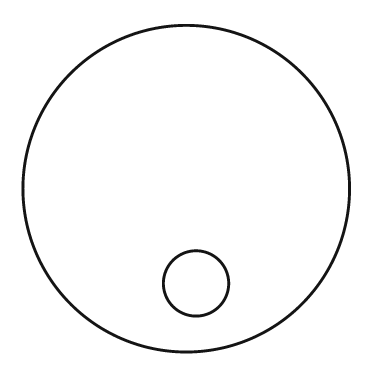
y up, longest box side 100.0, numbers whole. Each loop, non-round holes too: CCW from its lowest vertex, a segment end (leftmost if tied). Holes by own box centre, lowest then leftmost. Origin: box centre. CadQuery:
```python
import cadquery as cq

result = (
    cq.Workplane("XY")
    .moveTo(0.0, 0.0)
    .circle(50.0)
    .moveTo(3.0, -29.0)
    .circle(10.0)
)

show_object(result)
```